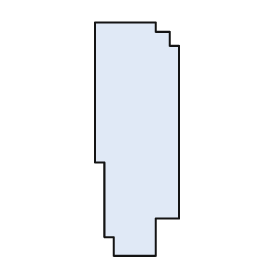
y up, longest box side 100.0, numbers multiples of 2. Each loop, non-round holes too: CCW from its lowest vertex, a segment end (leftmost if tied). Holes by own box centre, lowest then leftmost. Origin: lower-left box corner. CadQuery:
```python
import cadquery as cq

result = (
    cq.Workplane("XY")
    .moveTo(8.0, 0.0)
    .lineTo(26.0, 0.0)
    .lineTo(26.0, 16.0)
    .lineTo(36.0, 16.0)
    .lineTo(36.0, 90.0)
    .lineTo(32.0, 90.0)
    .lineTo(32.0, 96.0)
    .lineTo(26.0, 96.0)
    .lineTo(26.0, 100.0)
    .lineTo(0.0, 100.0)
    .lineTo(0.0, 40.0)
    .lineTo(4.0, 40.0)
    .lineTo(4.0, 8.0)
    .lineTo(8.0, 8.0)
    .close()
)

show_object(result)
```